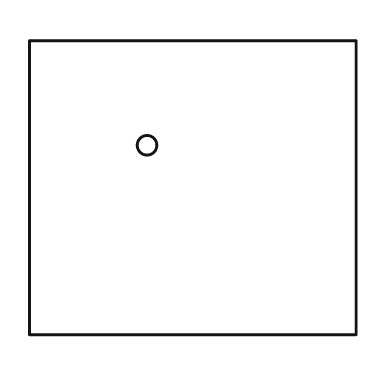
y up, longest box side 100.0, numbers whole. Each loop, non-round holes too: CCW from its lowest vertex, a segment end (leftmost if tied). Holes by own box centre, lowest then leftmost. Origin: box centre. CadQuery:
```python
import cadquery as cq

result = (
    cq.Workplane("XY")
    .moveTo(-50.0, -45.0)
    .lineTo(50.0, -45.0)
    .lineTo(50.0, 45.0)
    .lineTo(-50.0, 45.0)
    .close()
    .moveTo(-14.0, 13.0)
    .circle(3.0)
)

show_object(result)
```